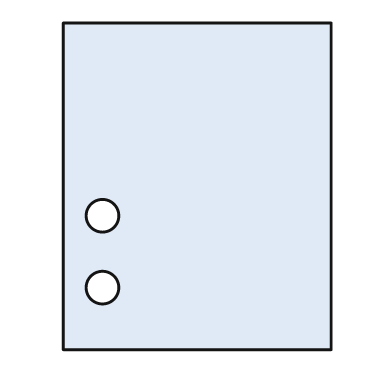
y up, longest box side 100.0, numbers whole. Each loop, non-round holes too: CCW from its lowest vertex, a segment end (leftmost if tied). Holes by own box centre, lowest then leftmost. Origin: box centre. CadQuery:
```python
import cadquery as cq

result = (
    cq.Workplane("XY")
    .moveTo(-41.0, -50.0)
    .lineTo(41.0, -50.0)
    .lineTo(41.0, 50.0)
    .lineTo(-41.0, 50.0)
    .close()
    .moveTo(-29.0, -31.0)
    .circle(5.0)
    .moveTo(-29.0, -9.0)
    .circle(5.0)
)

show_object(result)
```